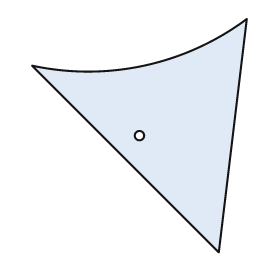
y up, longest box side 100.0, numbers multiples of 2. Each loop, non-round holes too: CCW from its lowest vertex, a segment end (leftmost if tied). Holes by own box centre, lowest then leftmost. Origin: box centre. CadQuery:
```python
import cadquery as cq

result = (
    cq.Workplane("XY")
    .moveTo(34.0, -50.0)
    .lineTo(46.0, 50.0)
    .threePointArc((2.0, 30.0), (-46.0, 30.0))
    .close()
    .moveTo(0.0, 0.0)
    .circle(2.0)
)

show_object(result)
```